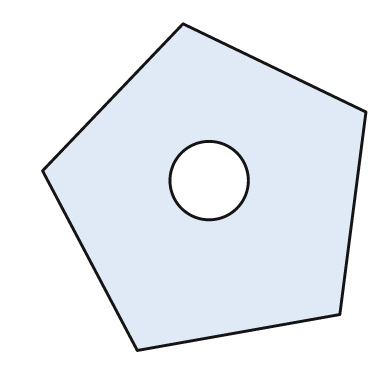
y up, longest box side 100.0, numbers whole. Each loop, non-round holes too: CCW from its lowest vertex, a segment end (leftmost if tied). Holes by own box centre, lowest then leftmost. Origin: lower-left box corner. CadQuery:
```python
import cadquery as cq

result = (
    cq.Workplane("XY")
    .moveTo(29.0, 0.0)
    .lineTo(91.0, 11.0)
    .lineTo(99.0, 73.0)
    .lineTo(43.0, 100.0)
    .lineTo(0.0, 55.0)
    .close()
    .moveTo(51.0, 52.0)
    .circle(12.0)
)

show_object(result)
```